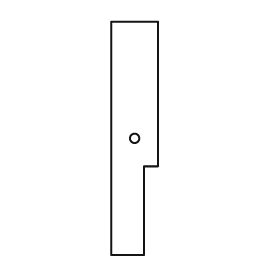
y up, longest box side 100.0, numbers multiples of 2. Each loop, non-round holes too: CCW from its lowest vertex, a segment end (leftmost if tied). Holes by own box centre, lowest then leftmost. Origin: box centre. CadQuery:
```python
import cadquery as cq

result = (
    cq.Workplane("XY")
    .moveTo(-10.0, -50.0)
    .lineTo(4.0, -50.0)
    .lineTo(4.0, -12.0)
    .lineTo(10.0, -12.0)
    .lineTo(10.0, 50.0)
    .lineTo(-10.0, 50.0)
    .close()
    .moveTo(0.0, 0.0)
    .circle(2.0)
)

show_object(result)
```